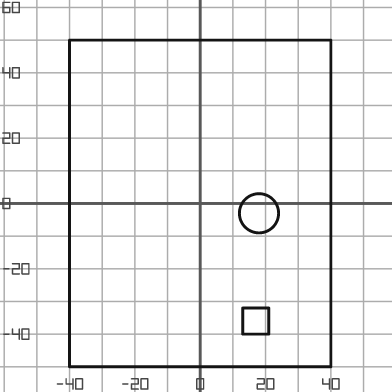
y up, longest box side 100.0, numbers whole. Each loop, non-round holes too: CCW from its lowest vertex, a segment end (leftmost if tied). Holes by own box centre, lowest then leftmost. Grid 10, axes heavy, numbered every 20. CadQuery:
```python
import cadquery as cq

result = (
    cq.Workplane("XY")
    .moveTo(-40.0, -50.0)
    .lineTo(40.0, -50.0)
    .lineTo(40.0, 50.0)
    .lineTo(-40.0, 50.0)
    .close()
    .moveTo(13.0, -40.0)
    .lineTo(21.0, -40.0)
    .lineTo(21.0, -32.0)
    .lineTo(13.0, -32.0)
    .close()
    .moveTo(18.0, -3.0)
    .circle(6.0)
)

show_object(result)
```